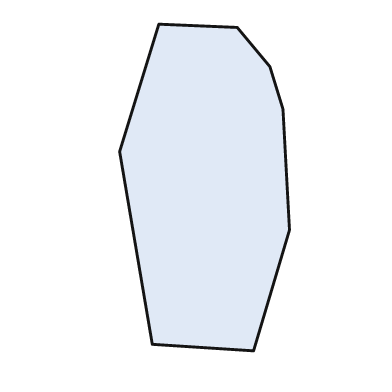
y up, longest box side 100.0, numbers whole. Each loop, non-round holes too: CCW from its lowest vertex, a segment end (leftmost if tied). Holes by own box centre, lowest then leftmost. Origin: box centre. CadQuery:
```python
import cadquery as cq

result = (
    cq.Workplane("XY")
    .moveTo(15.0, -50.0)
    .lineTo(26.0, -13.0)
    .lineTo(24.0, 24.0)
    .lineTo(20.0, 37.0)
    .lineTo(10.0, 49.0)
    .lineTo(-14.0, 50.0)
    .lineTo(-26.0, 11.0)
    .lineTo(-16.0, -48.0)
    .close()
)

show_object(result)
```